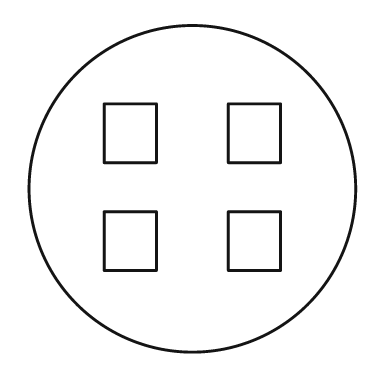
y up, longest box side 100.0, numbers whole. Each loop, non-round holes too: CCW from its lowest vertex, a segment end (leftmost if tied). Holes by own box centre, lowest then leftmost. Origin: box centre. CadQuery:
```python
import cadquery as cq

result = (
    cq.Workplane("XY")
    .moveTo(0.0, 0.0)
    .circle(50.0)
    .moveTo(-27.0, -25.0)
    .lineTo(-11.0, -25.0)
    .lineTo(-11.0, -7.0)
    .lineTo(-27.0, -7.0)
    .close()
    .moveTo(11.0, -25.0)
    .lineTo(27.0, -25.0)
    .lineTo(27.0, -7.0)
    .lineTo(11.0, -7.0)
    .close()
    .moveTo(-27.0, 8.0)
    .lineTo(-11.0, 8.0)
    .lineTo(-11.0, 26.0)
    .lineTo(-27.0, 26.0)
    .close()
    .moveTo(11.0, 8.0)
    .lineTo(27.0, 8.0)
    .lineTo(27.0, 26.0)
    .lineTo(11.0, 26.0)
    .close()
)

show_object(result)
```